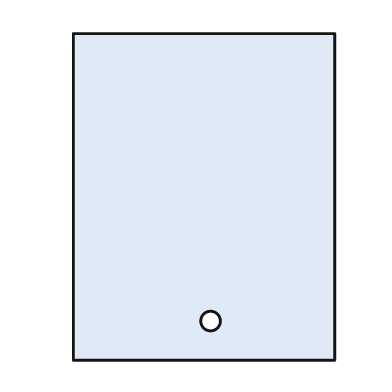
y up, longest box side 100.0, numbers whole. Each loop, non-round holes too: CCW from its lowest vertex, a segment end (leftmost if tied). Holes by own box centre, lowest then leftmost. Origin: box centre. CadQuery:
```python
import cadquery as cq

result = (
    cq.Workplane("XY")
    .moveTo(-40.0, -50.0)
    .lineTo(40.0, -50.0)
    .lineTo(40.0, 50.0)
    .lineTo(-40.0, 50.0)
    .close()
    .moveTo(2.0, -38.0)
    .circle(3.0)
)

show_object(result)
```